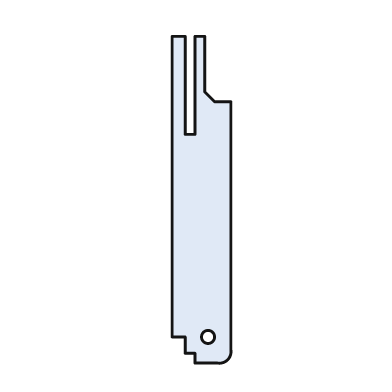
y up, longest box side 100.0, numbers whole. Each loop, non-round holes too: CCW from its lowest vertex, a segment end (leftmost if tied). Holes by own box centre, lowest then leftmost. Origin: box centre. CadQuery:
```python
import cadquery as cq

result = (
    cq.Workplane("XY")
    .moveTo(-2.0, -50.0)
    .lineTo(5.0, -50.0)
    .threePointArc((8.0, -49.0), (9.0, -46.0))
    .lineTo(9.0, 30.0)
    .lineTo(4.0, 30.0)
    .lineTo(1.0, 33.0)
    .lineTo(1.0, 50.0)
    .lineTo(-2.0, 50.0)
    .lineTo(-2.0, 20.0)
    .lineTo(-5.0, 20.0)
    .lineTo(-5.0, 50.0)
    .lineTo(-9.0, 50.0)
    .lineTo(-9.0, -42.0)
    .lineTo(-5.0, -42.0)
    .lineTo(-5.0, -47.0)
    .lineTo(-2.0, -47.0)
    .close()
    .moveTo(2.0, -42.0)
    .circle(2.0)
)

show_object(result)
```